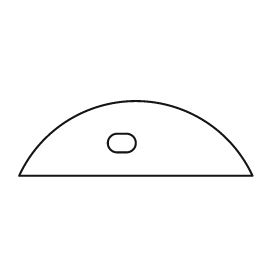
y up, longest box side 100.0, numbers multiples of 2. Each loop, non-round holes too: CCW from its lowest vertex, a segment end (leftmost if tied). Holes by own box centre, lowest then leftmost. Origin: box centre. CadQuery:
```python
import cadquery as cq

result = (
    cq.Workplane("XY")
    .moveTo(-50.0, -16.0)
    .lineTo(50.0, -16.0)
    .threePointArc((0.0, 16.0), (-50.0, -16.0))
    .close()
    .moveTo(-8.0, -6.0)
    .lineTo(-4.0, -6.0)
    .threePointArc((0.0, -2.0), (-4.0, 2.0))
    .lineTo(-8.0, 2.0)
    .threePointArc((-12.0, -2.0), (-8.0, -6.0))
    .close()
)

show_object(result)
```